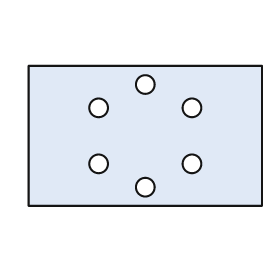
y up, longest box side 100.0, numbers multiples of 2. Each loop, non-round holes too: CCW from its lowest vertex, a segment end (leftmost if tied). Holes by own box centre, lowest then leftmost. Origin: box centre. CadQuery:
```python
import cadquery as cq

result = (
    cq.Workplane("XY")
    .moveTo(-50.0, -30.0)
    .lineTo(50.0, -30.0)
    .lineTo(50.0, 30.0)
    .lineTo(-50.0, 30.0)
    .close()
    .moveTo(0.0, -22.0)
    .circle(4.0)
    .moveTo(-20.0, -12.0)
    .circle(4.0)
    .moveTo(20.0, -12.0)
    .circle(4.0)
    .moveTo(-20.0, 12.0)
    .circle(4.0)
    .moveTo(20.0, 12.0)
    .circle(4.0)
    .moveTo(0.0, 22.0)
    .circle(4.0)
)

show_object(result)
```